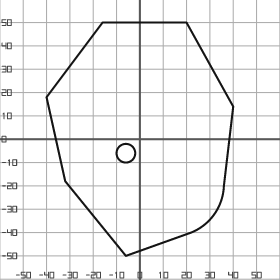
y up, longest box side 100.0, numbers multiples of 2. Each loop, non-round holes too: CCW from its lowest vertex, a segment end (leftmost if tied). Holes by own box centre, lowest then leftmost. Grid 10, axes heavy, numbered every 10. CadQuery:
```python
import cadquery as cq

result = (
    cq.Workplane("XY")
    .moveTo(-6.0, -50.0)
    .lineTo(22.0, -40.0)
    .threePointArc((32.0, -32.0), (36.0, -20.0))
    .lineTo(40.0, 14.0)
    .lineTo(20.0, 50.0)
    .lineTo(-16.0, 50.0)
    .lineTo(-40.0, 18.0)
    .lineTo(-32.0, -18.0)
    .close()
    .moveTo(-6.0, -6.0)
    .circle(4.0)
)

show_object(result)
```